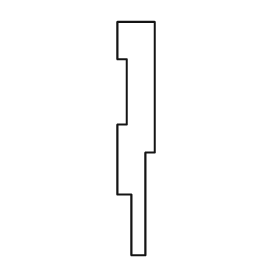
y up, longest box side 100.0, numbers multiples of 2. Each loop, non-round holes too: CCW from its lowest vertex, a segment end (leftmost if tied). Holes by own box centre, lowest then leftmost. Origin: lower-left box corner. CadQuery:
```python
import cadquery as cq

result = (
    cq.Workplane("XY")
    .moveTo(6.0, 0.0)
    .lineTo(12.0, 0.0)
    .lineTo(12.0, 44.0)
    .lineTo(16.0, 44.0)
    .lineTo(16.0, 100.0)
    .lineTo(0.0, 100.0)
    .lineTo(0.0, 84.0)
    .lineTo(4.0, 84.0)
    .lineTo(4.0, 56.0)
    .lineTo(0.0, 56.0)
    .lineTo(0.0, 26.0)
    .lineTo(6.0, 26.0)
    .close()
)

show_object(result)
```